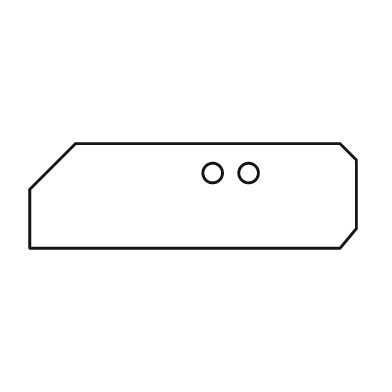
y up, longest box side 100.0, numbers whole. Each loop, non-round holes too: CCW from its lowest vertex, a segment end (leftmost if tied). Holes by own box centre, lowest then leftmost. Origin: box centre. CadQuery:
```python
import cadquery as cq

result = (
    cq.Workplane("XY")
    .moveTo(-50.0, -16.0)
    .lineTo(45.0, -16.0)
    .lineTo(50.0, -10.0)
    .lineTo(50.0, 11.0)
    .lineTo(45.0, 16.0)
    .lineTo(-36.0, 16.0)
    .lineTo(-50.0, 2.0)
    .close()
    .moveTo(6.0, 7.0)
    .circle(3.0)
    .moveTo(17.0, 7.0)
    .circle(3.0)
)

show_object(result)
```